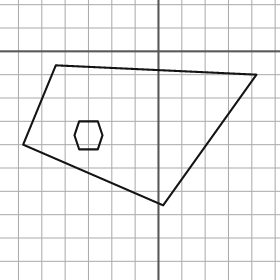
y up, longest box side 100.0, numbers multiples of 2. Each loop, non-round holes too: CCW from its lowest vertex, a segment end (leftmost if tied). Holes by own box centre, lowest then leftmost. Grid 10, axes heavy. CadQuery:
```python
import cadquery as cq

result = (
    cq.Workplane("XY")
    .moveTo(2.0, -66.0)
    .lineTo(42.0, -10.0)
    .lineTo(-44.0, -6.0)
    .lineTo(-58.0, -40.0)
    .close()
    .moveTo(-34.0, -42.0)
    .lineTo(-26.0, -42.0)
    .lineTo(-24.0, -36.0)
    .lineTo(-26.0, -30.0)
    .lineTo(-34.0, -30.0)
    .lineTo(-36.0, -36.0)
    .close()
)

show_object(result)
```